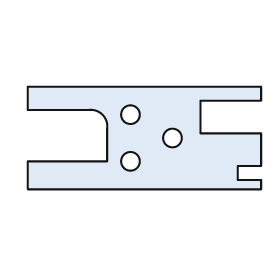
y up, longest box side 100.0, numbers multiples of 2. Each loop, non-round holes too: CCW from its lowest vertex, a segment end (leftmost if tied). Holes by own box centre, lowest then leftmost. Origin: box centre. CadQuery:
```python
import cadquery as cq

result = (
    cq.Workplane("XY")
    .moveTo(-50.0, -22.0)
    .lineTo(50.0, -22.0)
    .lineTo(50.0, -18.0)
    .lineTo(40.0, -18.0)
    .lineTo(40.0, -12.0)
    .lineTo(50.0, -12.0)
    .lineTo(50.0, 2.0)
    .lineTo(24.0, 2.0)
    .lineTo(24.0, 16.0)
    .lineTo(50.0, 16.0)
    .lineTo(50.0, 22.0)
    .lineTo(-50.0, 22.0)
    .lineTo(-50.0, 12.0)
    .lineTo(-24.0, 12.0)
    .threePointArc((-18.0, 10.0), (-16.0, 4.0))
    .lineTo(-16.0, -10.0)
    .lineTo(-50.0, -10.0)
    .close()
    .moveTo(-6.0, -10.0)
    .circle(4.0)
    .moveTo(12.0, 0.0)
    .circle(4.0)
    .moveTo(-6.0, 10.0)
    .circle(4.0)
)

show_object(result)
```